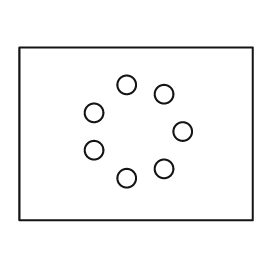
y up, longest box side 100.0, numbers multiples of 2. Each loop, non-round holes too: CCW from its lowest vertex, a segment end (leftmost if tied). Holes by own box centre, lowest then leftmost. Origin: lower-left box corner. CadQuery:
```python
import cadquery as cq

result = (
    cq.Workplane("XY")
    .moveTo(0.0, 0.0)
    .lineTo(100.0, 0.0)
    .lineTo(100.0, 74.0)
    .lineTo(0.0, 74.0)
    .close()
    .moveTo(46.0, 18.0)
    .circle(4.0)
    .moveTo(62.0, 22.0)
    .circle(4.0)
    .moveTo(32.0, 30.0)
    .circle(4.0)
    .moveTo(70.0, 38.0)
    .circle(4.0)
    .moveTo(32.0, 46.0)
    .circle(4.0)
    .moveTo(62.0, 54.0)
    .circle(4.0)
    .moveTo(46.0, 58.0)
    .circle(4.0)
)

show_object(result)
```